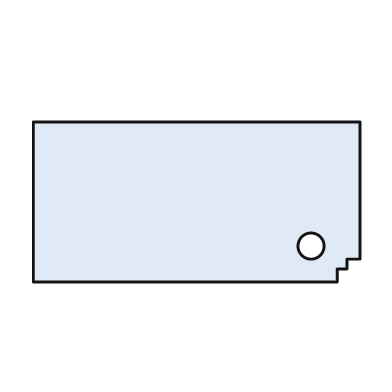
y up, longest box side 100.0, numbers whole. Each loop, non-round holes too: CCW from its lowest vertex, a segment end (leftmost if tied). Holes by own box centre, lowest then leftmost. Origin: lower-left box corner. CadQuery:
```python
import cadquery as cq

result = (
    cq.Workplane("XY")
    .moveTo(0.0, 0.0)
    .lineTo(93.0, 0.0)
    .lineTo(93.0, 4.0)
    .lineTo(96.0, 4.0)
    .lineTo(96.0, 7.0)
    .lineTo(100.0, 7.0)
    .lineTo(100.0, 49.0)
    .lineTo(0.0, 49.0)
    .close()
    .moveTo(85.0, 11.0)
    .circle(4.0)
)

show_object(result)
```